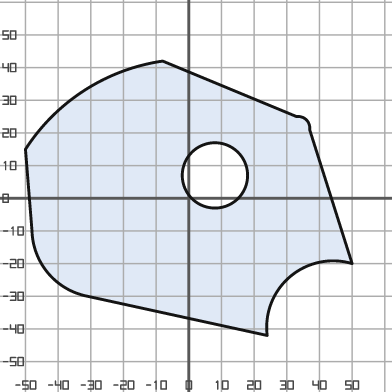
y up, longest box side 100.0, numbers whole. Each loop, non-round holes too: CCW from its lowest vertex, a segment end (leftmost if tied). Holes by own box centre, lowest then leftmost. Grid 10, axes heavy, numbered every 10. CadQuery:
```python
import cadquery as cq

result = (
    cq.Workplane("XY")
    .moveTo(24.0, -42.0)
    .threePointArc((31.0, -24.0), (50.0, -20.0))
    .lineTo(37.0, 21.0)
    .threePointArc((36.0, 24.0), (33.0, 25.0))
    .lineTo(-8.0, 42.0)
    .threePointArc((-32.0, 33.0), (-50.0, 15.0))
    .lineTo(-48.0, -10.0)
    .threePointArc((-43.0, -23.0), (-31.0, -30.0))
    .close()
    .moveTo(8.0, 7.0)
    .circle(10.0)
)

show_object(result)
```